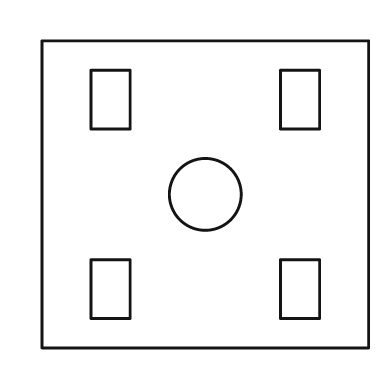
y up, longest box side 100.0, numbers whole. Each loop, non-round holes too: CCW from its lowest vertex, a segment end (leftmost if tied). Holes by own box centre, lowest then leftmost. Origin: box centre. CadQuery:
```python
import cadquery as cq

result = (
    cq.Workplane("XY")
    .moveTo(-50.0, -47.0)
    .lineTo(50.0, -47.0)
    .lineTo(50.0, 47.0)
    .lineTo(-50.0, 47.0)
    .close()
    .moveTo(-35.0, -38.0)
    .lineTo(-23.0, -38.0)
    .lineTo(-23.0, -20.0)
    .lineTo(-35.0, -20.0)
    .close()
    .moveTo(23.0, -38.0)
    .lineTo(35.0, -38.0)
    .lineTo(35.0, -20.0)
    .lineTo(23.0, -20.0)
    .close()
    .moveTo(0.0, 0.0)
    .circle(11.0)
    .moveTo(-35.0, 20.0)
    .lineTo(-23.0, 20.0)
    .lineTo(-23.0, 38.0)
    .lineTo(-35.0, 38.0)
    .close()
    .moveTo(23.0, 20.0)
    .lineTo(35.0, 20.0)
    .lineTo(35.0, 38.0)
    .lineTo(23.0, 38.0)
    .close()
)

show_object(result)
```